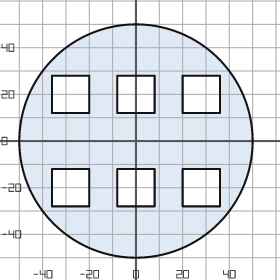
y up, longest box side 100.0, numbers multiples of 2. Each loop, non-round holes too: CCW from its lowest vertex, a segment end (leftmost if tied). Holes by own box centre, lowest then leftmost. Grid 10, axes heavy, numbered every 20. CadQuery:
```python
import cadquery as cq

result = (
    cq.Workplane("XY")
    .moveTo(0.0, 0.0)
    .circle(50.0)
    .moveTo(-36.0, -28.0)
    .lineTo(-20.0, -28.0)
    .lineTo(-20.0, -12.0)
    .lineTo(-36.0, -12.0)
    .close()
    .moveTo(-8.0, -28.0)
    .lineTo(8.0, -28.0)
    .lineTo(8.0, -12.0)
    .lineTo(-8.0, -12.0)
    .close()
    .moveTo(20.0, -28.0)
    .lineTo(36.0, -28.0)
    .lineTo(36.0, -12.0)
    .lineTo(20.0, -12.0)
    .close()
    .moveTo(-36.0, 12.0)
    .lineTo(-20.0, 12.0)
    .lineTo(-20.0, 28.0)
    .lineTo(-36.0, 28.0)
    .close()
    .moveTo(-8.0, 12.0)
    .lineTo(8.0, 12.0)
    .lineTo(8.0, 28.0)
    .lineTo(-8.0, 28.0)
    .close()
    .moveTo(20.0, 12.0)
    .lineTo(36.0, 12.0)
    .lineTo(36.0, 28.0)
    .lineTo(20.0, 28.0)
    .close()
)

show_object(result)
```